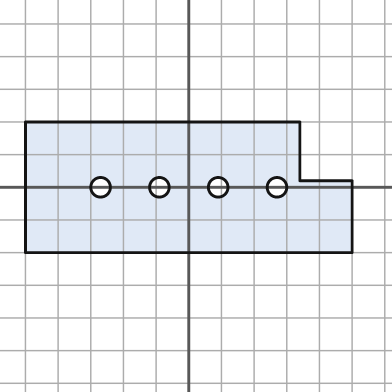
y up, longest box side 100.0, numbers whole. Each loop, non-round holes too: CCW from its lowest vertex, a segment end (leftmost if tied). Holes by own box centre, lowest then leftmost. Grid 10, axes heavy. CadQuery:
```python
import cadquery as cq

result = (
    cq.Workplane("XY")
    .moveTo(-50.0, -20.0)
    .lineTo(50.0, -20.0)
    .lineTo(50.0, 2.0)
    .lineTo(34.0, 2.0)
    .lineTo(34.0, 20.0)
    .lineTo(-50.0, 20.0)
    .close()
    .moveTo(-27.0, 0.0)
    .circle(3.0)
    .moveTo(-9.0, 0.0)
    .circle(3.0)
    .moveTo(9.0, 0.0)
    .circle(3.0)
    .moveTo(27.0, 0.0)
    .circle(3.0)
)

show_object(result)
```